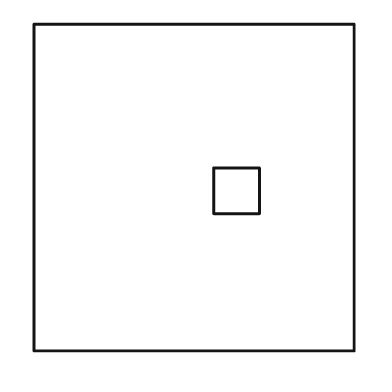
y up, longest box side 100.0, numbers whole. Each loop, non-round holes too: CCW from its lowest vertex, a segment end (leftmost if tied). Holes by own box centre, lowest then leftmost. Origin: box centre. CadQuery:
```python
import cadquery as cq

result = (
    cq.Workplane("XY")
    .moveTo(-49.0, -50.0)
    .lineTo(49.0, -50.0)
    .lineTo(49.0, 50.0)
    .lineTo(-49.0, 50.0)
    .close()
    .moveTo(6.0, -8.0)
    .lineTo(20.0, -8.0)
    .lineTo(20.0, 6.0)
    .lineTo(6.0, 6.0)
    .close()
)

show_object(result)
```